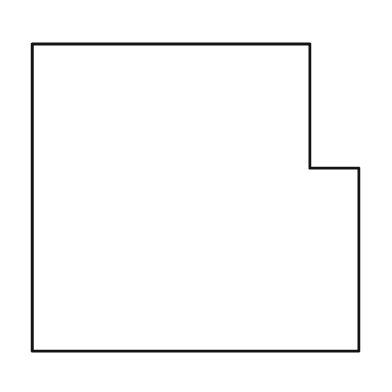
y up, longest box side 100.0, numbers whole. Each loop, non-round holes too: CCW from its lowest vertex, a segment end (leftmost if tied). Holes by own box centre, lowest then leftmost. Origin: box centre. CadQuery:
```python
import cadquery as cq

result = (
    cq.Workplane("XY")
    .moveTo(-50.0, -47.0)
    .lineTo(50.0, -47.0)
    .lineTo(50.0, 9.0)
    .lineTo(35.0, 9.0)
    .lineTo(35.0, 47.0)
    .lineTo(-50.0, 47.0)
    .close()
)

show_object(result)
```